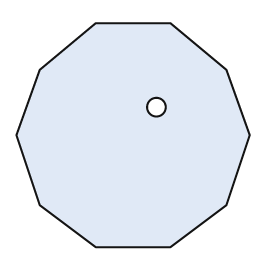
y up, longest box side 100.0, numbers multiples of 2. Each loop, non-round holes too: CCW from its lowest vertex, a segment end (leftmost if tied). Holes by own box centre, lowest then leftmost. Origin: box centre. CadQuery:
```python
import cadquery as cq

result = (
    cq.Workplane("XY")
    .moveTo(-16.0, -48.0)
    .lineTo(16.0, -48.0)
    .lineTo(40.0, -30.0)
    .lineTo(50.0, 0.0)
    .lineTo(40.0, 28.0)
    .lineTo(16.0, 48.0)
    .lineTo(-16.0, 48.0)
    .lineTo(-40.0, 28.0)
    .lineTo(-50.0, 0.0)
    .lineTo(-40.0, -30.0)
    .close()
    .moveTo(10.0, 12.0)
    .circle(4.0)
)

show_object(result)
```